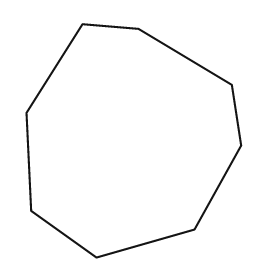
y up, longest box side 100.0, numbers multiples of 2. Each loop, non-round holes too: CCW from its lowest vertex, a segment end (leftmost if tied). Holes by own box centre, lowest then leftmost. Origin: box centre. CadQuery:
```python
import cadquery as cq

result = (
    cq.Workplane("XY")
    .moveTo(-16.0, -50.0)
    .lineTo(26.0, -38.0)
    .lineTo(46.0, -2.0)
    .lineTo(42.0, 24.0)
    .lineTo(2.0, 48.0)
    .lineTo(-22.0, 50.0)
    .lineTo(-46.0, 12.0)
    .lineTo(-44.0, -30.0)
    .close()
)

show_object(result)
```